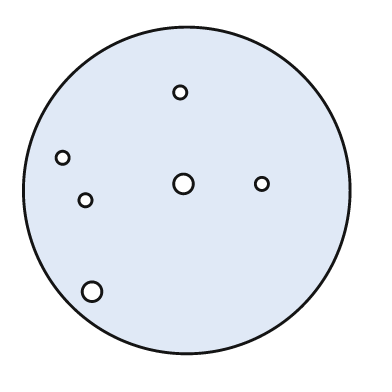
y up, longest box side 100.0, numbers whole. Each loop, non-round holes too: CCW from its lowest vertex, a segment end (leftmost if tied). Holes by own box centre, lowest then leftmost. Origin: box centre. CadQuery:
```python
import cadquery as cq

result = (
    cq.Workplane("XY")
    .moveTo(0.0, 0.0)
    .circle(50.0)
    .moveTo(-29.0, -31.0)
    .circle(3.0)
    .moveTo(-31.0, -3.0)
    .circle(2.0)
    .moveTo(-1.0, 2.0)
    .circle(3.0)
    .moveTo(23.0, 2.0)
    .circle(2.0)
    .moveTo(-38.0, 10.0)
    .circle(2.0)
    .moveTo(-2.0, 30.0)
    .circle(2.0)
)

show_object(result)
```